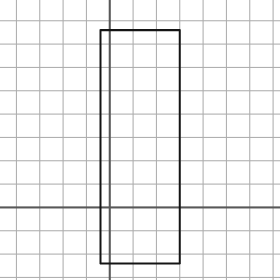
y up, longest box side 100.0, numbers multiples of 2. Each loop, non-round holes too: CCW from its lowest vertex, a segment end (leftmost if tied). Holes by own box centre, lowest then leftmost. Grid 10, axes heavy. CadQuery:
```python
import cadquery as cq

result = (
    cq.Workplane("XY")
    .moveTo(-4.0, -24.0)
    .lineTo(30.0, -24.0)
    .lineTo(30.0, 76.0)
    .lineTo(-4.0, 76.0)
    .close()
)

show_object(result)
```